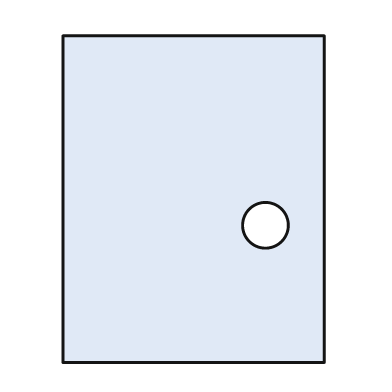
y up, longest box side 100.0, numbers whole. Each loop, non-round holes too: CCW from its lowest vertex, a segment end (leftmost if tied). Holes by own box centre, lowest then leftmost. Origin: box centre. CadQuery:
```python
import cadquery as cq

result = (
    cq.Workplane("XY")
    .moveTo(-40.0, -50.0)
    .lineTo(40.0, -50.0)
    .lineTo(40.0, 50.0)
    .lineTo(-40.0, 50.0)
    .close()
    .moveTo(22.0, -8.0)
    .circle(7.0)
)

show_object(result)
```